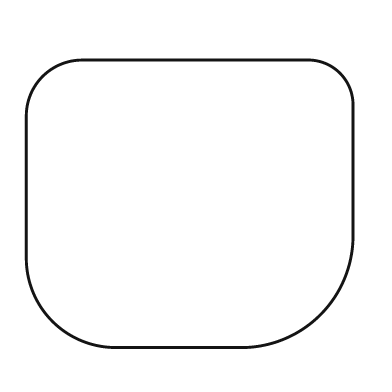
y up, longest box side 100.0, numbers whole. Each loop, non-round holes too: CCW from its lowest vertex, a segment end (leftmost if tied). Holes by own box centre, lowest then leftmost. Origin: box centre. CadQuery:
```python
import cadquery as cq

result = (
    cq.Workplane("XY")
    .moveTo(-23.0, -44.0)
    .lineTo(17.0, -44.0)
    .threePointArc((40.0, -34.0), (50.0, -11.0))
    .lineTo(50.0, 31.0)
    .threePointArc((46.0, 40.0), (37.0, 44.0))
    .lineTo(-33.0, 44.0)
    .threePointArc((-45.0, 39.0), (-50.0, 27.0))
    .lineTo(-50.0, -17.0)
    .threePointArc((-42.0, -36.0), (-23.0, -44.0))
    .close()
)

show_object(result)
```